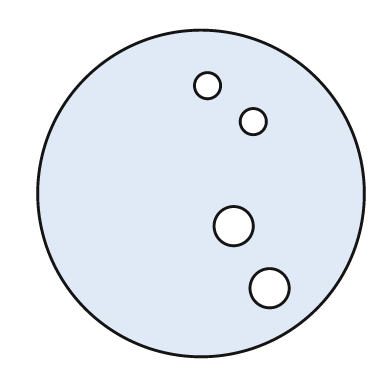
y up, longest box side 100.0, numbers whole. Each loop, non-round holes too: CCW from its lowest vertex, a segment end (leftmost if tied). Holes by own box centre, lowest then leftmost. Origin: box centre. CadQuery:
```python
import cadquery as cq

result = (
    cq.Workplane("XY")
    .moveTo(0.0, 0.0)
    .circle(50.0)
    .moveTo(21.0, -29.0)
    .circle(6.0)
    .moveTo(10.0, -10.0)
    .circle(6.0)
    .moveTo(16.0, 22.0)
    .circle(4.0)
    .moveTo(2.0, 33.0)
    .circle(4.0)
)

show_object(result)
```